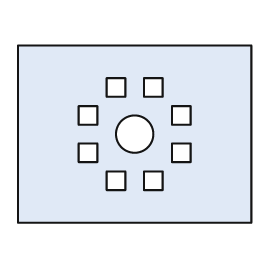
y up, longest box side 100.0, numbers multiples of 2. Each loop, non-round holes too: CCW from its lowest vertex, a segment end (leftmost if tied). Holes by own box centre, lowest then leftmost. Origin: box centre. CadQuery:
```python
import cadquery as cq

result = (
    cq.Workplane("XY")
    .moveTo(-50.0, -38.0)
    .lineTo(50.0, -38.0)
    .lineTo(50.0, 38.0)
    .lineTo(-50.0, 38.0)
    .close()
    .moveTo(-12.0, -24.0)
    .lineTo(-4.0, -24.0)
    .lineTo(-4.0, -16.0)
    .lineTo(-12.0, -16.0)
    .close()
    .moveTo(4.0, -24.0)
    .lineTo(12.0, -24.0)
    .lineTo(12.0, -16.0)
    .lineTo(4.0, -16.0)
    .close()
    .moveTo(-24.0, -12.0)
    .lineTo(-16.0, -12.0)
    .lineTo(-16.0, -4.0)
    .lineTo(-24.0, -4.0)
    .close()
    .moveTo(16.0, -12.0)
    .lineTo(24.0, -12.0)
    .lineTo(24.0, -4.0)
    .lineTo(16.0, -4.0)
    .close()
    .moveTo(0.0, 0.0)
    .circle(8.0)
    .moveTo(-24.0, 4.0)
    .lineTo(-16.0, 4.0)
    .lineTo(-16.0, 12.0)
    .lineTo(-24.0, 12.0)
    .close()
    .moveTo(16.0, 4.0)
    .lineTo(24.0, 4.0)
    .lineTo(24.0, 12.0)
    .lineTo(16.0, 12.0)
    .close()
    .moveTo(-12.0, 16.0)
    .lineTo(-4.0, 16.0)
    .lineTo(-4.0, 24.0)
    .lineTo(-12.0, 24.0)
    .close()
    .moveTo(4.0, 16.0)
    .lineTo(12.0, 16.0)
    .lineTo(12.0, 24.0)
    .lineTo(4.0, 24.0)
    .close()
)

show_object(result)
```